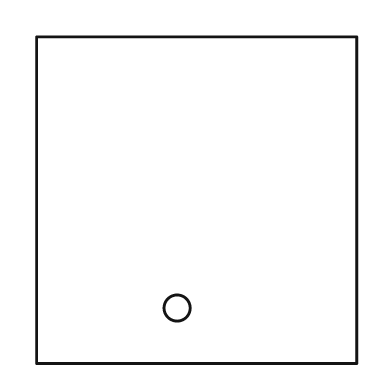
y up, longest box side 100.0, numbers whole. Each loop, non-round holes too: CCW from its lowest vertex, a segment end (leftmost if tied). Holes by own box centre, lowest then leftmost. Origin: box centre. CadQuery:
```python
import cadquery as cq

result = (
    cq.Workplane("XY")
    .moveTo(-49.0, -50.0)
    .lineTo(49.0, -50.0)
    .lineTo(49.0, 50.0)
    .lineTo(-49.0, 50.0)
    .close()
    .moveTo(-6.0, -33.0)
    .circle(4.0)
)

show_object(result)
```